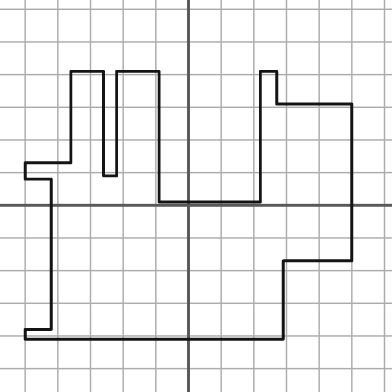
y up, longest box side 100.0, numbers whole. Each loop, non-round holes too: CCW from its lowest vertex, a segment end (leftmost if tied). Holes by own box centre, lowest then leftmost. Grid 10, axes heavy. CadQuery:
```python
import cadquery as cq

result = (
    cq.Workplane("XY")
    .moveTo(-50.0, -41.0)
    .lineTo(29.0, -41.0)
    .lineTo(29.0, -17.0)
    .lineTo(50.0, -17.0)
    .lineTo(50.0, 31.0)
    .lineTo(27.0, 31.0)
    .lineTo(27.0, 41.0)
    .lineTo(22.0, 41.0)
    .lineTo(22.0, 1.0)
    .lineTo(-9.0, 1.0)
    .lineTo(-9.0, 41.0)
    .lineTo(-22.0, 41.0)
    .lineTo(-22.0, 9.0)
    .lineTo(-26.0, 9.0)
    .lineTo(-26.0, 41.0)
    .lineTo(-36.0, 41.0)
    .lineTo(-36.0, 13.0)
    .lineTo(-50.0, 13.0)
    .lineTo(-50.0, 8.0)
    .lineTo(-42.0, 8.0)
    .lineTo(-42.0, -38.0)
    .lineTo(-50.0, -38.0)
    .close()
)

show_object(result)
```